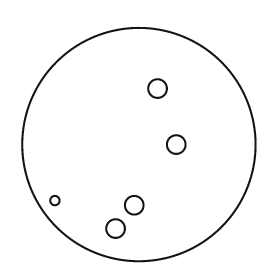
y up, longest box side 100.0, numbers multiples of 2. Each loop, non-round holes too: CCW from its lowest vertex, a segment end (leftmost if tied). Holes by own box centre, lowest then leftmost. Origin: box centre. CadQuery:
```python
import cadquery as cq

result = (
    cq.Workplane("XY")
    .moveTo(0.0, 0.0)
    .circle(50.0)
    .moveTo(-10.0, -36.0)
    .circle(4.0)
    .moveTo(-2.0, -26.0)
    .circle(4.0)
    .moveTo(-36.0, -24.0)
    .circle(2.0)
    .moveTo(16.0, 0.0)
    .circle(4.0)
    .moveTo(8.0, 24.0)
    .circle(4.0)
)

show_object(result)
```